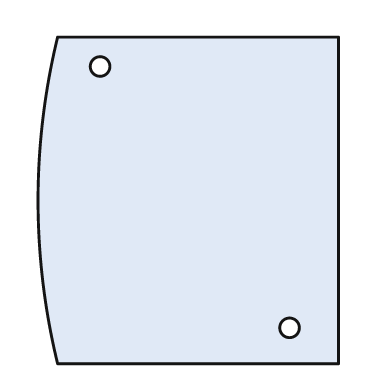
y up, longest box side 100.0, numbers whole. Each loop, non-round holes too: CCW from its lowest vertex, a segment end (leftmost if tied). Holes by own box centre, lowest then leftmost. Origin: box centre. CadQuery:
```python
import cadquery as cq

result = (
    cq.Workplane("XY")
    .moveTo(-40.0, -50.0)
    .lineTo(46.0, -50.0)
    .lineTo(46.0, 50.0)
    .lineTo(-40.0, 50.0)
    .threePointArc((-46.0, 0.0), (-40.0, -50.0))
    .close()
    .moveTo(31.0, -39.0)
    .circle(3.0)
    .moveTo(-27.0, 41.0)
    .circle(3.0)
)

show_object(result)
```